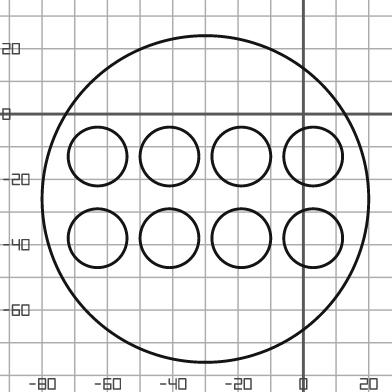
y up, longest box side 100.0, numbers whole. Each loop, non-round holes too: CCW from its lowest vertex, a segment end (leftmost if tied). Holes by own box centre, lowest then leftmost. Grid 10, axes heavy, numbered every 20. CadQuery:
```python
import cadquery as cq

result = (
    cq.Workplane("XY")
    .moveTo(-30.0, -26.0)
    .circle(50.0)
    .moveTo(-63.0, -38.0)
    .circle(9.0)
    .moveTo(-41.0, -38.0)
    .circle(9.0)
    .moveTo(-19.0, -38.0)
    .circle(9.0)
    .moveTo(3.0, -38.0)
    .circle(9.0)
    .moveTo(-63.0, -13.0)
    .circle(9.0)
    .moveTo(-41.0, -13.0)
    .circle(9.0)
    .moveTo(-19.0, -13.0)
    .circle(9.0)
    .moveTo(3.0, -13.0)
    .circle(9.0)
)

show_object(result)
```